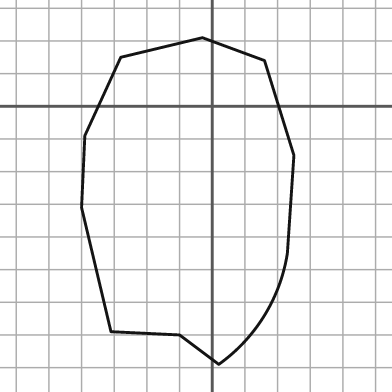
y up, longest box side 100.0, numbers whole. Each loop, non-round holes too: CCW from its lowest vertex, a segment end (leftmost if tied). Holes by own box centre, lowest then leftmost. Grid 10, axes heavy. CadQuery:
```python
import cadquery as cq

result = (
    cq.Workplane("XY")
    .moveTo(2.0, -79.0)
    .threePointArc((16.0, -64.0), (23.0, -45.0))
    .lineTo(25.0, -15.0)
    .lineTo(16.0, 14.0)
    .lineTo(-3.0, 21.0)
    .lineTo(-28.0, 15.0)
    .lineTo(-39.0, -9.0)
    .lineTo(-40.0, -31.0)
    .lineTo(-31.0, -69.0)
    .lineTo(-10.0, -70.0)
    .close()
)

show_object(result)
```